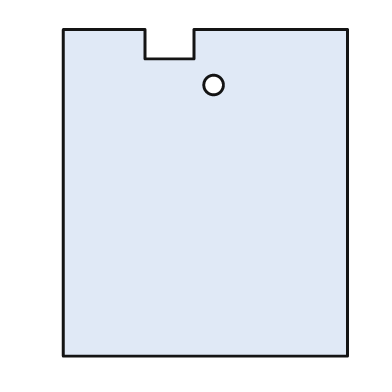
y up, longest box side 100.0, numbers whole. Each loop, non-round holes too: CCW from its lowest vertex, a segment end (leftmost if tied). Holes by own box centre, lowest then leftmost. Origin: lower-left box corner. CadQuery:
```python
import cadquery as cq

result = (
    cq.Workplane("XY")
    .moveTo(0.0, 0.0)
    .lineTo(87.0, 0.0)
    .lineTo(87.0, 100.0)
    .lineTo(40.0, 100.0)
    .lineTo(40.0, 91.0)
    .lineTo(25.0, 91.0)
    .lineTo(25.0, 100.0)
    .lineTo(0.0, 100.0)
    .close()
    .moveTo(46.0, 83.0)
    .circle(3.0)
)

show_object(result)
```